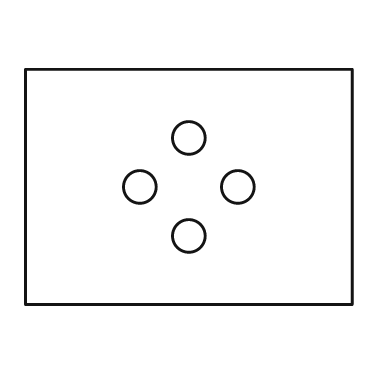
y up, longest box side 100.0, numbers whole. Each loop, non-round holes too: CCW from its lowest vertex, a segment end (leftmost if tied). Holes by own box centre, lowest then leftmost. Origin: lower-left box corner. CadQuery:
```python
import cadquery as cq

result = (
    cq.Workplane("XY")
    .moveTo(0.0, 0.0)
    .lineTo(100.0, 0.0)
    .lineTo(100.0, 72.0)
    .lineTo(0.0, 72.0)
    .close()
    .moveTo(50.0, 21.0)
    .circle(5.0)
    .moveTo(35.0, 36.0)
    .circle(5.0)
    .moveTo(65.0, 36.0)
    .circle(5.0)
    .moveTo(50.0, 51.0)
    .circle(5.0)
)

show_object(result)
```